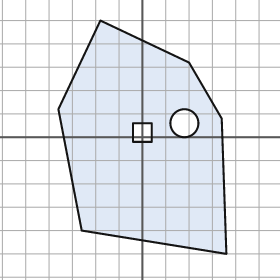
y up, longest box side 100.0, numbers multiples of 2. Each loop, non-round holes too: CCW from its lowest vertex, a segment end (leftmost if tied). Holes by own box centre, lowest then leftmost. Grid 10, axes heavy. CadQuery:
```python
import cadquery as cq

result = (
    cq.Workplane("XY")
    .moveTo(36.0, -50.0)
    .lineTo(34.0, 8.0)
    .lineTo(20.0, 32.0)
    .lineTo(-18.0, 50.0)
    .lineTo(-36.0, 12.0)
    .lineTo(-26.0, -40.0)
    .close()
    .moveTo(-4.0, -2.0)
    .lineTo(4.0, -2.0)
    .lineTo(4.0, 6.0)
    .lineTo(-4.0, 6.0)
    .close()
    .moveTo(18.0, 6.0)
    .circle(6.0)
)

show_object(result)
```